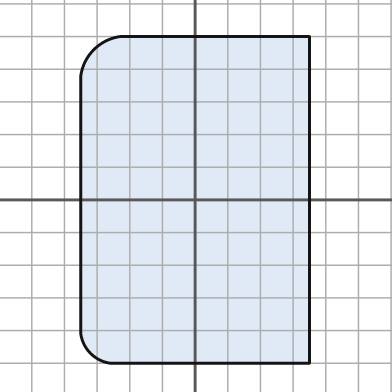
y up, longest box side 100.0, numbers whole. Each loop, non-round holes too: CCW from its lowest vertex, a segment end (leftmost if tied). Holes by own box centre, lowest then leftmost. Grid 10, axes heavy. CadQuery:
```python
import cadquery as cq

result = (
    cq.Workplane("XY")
    .moveTo(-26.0, -50.0)
    .lineTo(35.0, -50.0)
    .lineTo(35.0, 50.0)
    .lineTo(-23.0, 50.0)
    .threePointArc((-31.0, 46.0), (-35.0, 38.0))
    .lineTo(-35.0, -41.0)
    .threePointArc((-32.0, -47.0), (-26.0, -50.0))
    .close()
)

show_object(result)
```